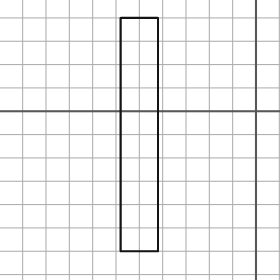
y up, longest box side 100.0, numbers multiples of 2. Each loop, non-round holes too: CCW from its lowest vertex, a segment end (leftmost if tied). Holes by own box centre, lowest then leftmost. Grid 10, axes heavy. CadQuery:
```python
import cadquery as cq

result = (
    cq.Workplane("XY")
    .moveTo(-58.0, -60.0)
    .lineTo(-42.0, -60.0)
    .lineTo(-42.0, 40.0)
    .lineTo(-58.0, 40.0)
    .close()
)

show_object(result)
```